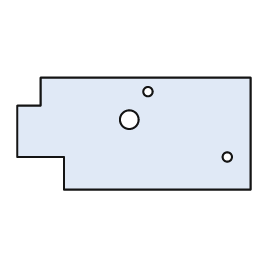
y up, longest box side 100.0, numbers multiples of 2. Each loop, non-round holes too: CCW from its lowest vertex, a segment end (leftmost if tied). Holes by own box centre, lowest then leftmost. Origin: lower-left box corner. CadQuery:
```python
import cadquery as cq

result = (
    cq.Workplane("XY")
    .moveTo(20.0, 0.0)
    .lineTo(100.0, 0.0)
    .lineTo(100.0, 48.0)
    .lineTo(10.0, 48.0)
    .lineTo(10.0, 36.0)
    .lineTo(0.0, 36.0)
    .lineTo(0.0, 14.0)
    .lineTo(20.0, 14.0)
    .close()
    .moveTo(90.0, 14.0)
    .circle(2.0)
    .moveTo(48.0, 30.0)
    .circle(4.0)
    .moveTo(56.0, 42.0)
    .circle(2.0)
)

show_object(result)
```